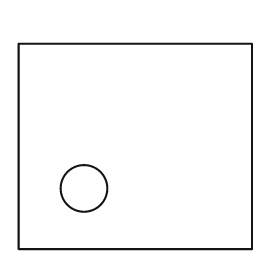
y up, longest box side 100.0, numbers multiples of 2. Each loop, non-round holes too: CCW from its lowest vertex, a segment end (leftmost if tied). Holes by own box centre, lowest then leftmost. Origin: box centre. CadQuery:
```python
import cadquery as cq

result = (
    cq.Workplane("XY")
    .moveTo(-50.0, -44.0)
    .lineTo(50.0, -44.0)
    .lineTo(50.0, 44.0)
    .lineTo(-50.0, 44.0)
    .close()
    .moveTo(-22.0, -18.0)
    .circle(10.0)
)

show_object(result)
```